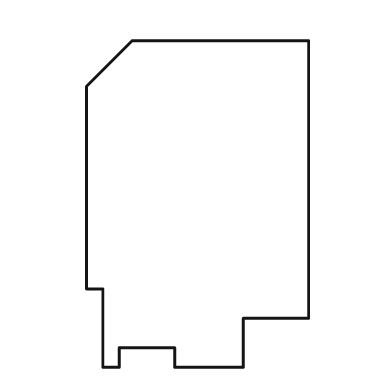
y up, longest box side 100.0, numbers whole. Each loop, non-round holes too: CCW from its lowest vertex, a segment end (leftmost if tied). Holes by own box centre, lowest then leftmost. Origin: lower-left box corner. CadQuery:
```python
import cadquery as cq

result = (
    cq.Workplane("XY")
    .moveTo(5.0, 0.0)
    .lineTo(10.0, 0.0)
    .lineTo(10.0, 6.0)
    .lineTo(27.0, 6.0)
    .lineTo(27.0, 0.0)
    .lineTo(48.0, 0.0)
    .lineTo(48.0, 15.0)
    .lineTo(68.0, 15.0)
    .lineTo(68.0, 100.0)
    .lineTo(14.0, 100.0)
    .lineTo(0.0, 86.0)
    .lineTo(0.0, 24.0)
    .lineTo(5.0, 24.0)
    .close()
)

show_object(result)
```